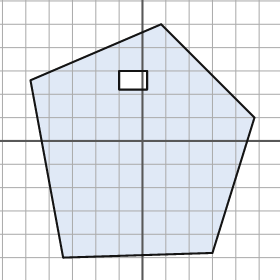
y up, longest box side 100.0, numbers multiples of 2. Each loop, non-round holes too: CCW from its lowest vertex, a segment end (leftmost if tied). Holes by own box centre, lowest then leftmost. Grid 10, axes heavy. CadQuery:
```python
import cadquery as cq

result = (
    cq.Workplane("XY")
    .moveTo(-34.0, -50.0)
    .lineTo(30.0, -48.0)
    .lineTo(48.0, 10.0)
    .lineTo(8.0, 50.0)
    .lineTo(-48.0, 26.0)
    .close()
    .moveTo(-10.0, 22.0)
    .lineTo(2.0, 22.0)
    .lineTo(2.0, 30.0)
    .lineTo(-10.0, 30.0)
    .close()
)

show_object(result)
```